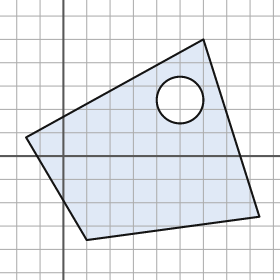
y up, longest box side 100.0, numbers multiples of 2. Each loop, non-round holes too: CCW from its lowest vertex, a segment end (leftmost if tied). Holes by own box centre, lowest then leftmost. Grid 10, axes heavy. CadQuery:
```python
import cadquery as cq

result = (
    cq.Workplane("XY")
    .moveTo(10.0, -36.0)
    .lineTo(84.0, -26.0)
    .lineTo(60.0, 50.0)
    .lineTo(-16.0, 8.0)
    .close()
    .moveTo(50.0, 24.0)
    .circle(10.0)
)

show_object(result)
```